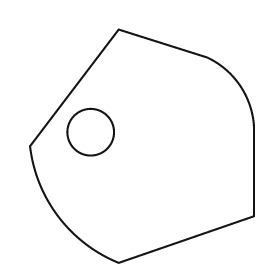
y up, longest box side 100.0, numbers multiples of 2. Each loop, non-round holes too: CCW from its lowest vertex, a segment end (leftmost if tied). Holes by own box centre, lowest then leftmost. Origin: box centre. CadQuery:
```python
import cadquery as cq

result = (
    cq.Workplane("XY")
    .moveTo(-10.0, -50.0)
    .lineTo(48.0, -30.0)
    .lineTo(48.0, 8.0)
    .threePointArc((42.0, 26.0), (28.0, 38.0))
    .lineTo(-10.0, 50.0)
    .lineTo(-48.0, 0.0)
    .threePointArc((-36.0, -30.0), (-10.0, -50.0))
    .close()
    .moveTo(-22.0, 6.0)
    .circle(10.0)
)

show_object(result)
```